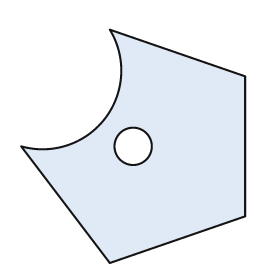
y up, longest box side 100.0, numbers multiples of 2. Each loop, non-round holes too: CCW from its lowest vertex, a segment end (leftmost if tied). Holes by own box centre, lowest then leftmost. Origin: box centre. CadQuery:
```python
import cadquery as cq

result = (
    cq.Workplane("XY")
    .moveTo(-10.0, -50.0)
    .lineTo(48.0, -30.0)
    .lineTo(48.0, 30.0)
    .lineTo(-10.0, 50.0)
    .threePointArc((-12.0, 12.0), (-48.0, 0.0))
    .close()
    .moveTo(0.0, 0.0)
    .circle(8.0)
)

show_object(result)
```